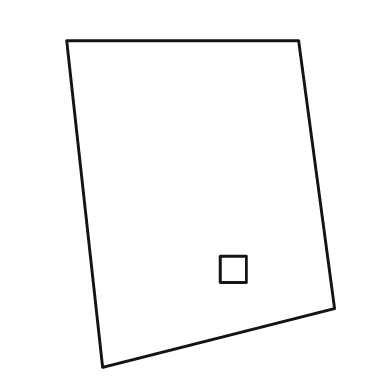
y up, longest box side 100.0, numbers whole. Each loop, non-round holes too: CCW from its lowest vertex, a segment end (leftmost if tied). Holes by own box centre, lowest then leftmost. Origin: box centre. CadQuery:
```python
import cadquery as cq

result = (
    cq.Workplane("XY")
    .moveTo(-30.0, -50.0)
    .lineTo(41.0, -32.0)
    .lineTo(30.0, 50.0)
    .lineTo(-41.0, 50.0)
    .close()
    .moveTo(6.0, -24.0)
    .lineTo(14.0, -24.0)
    .lineTo(14.0, -16.0)
    .lineTo(6.0, -16.0)
    .close()
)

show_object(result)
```